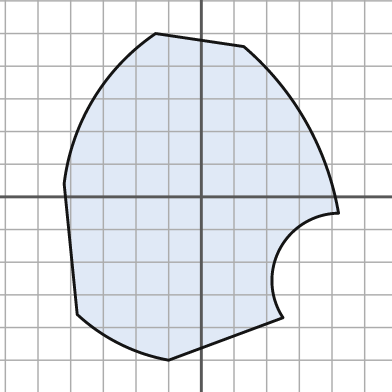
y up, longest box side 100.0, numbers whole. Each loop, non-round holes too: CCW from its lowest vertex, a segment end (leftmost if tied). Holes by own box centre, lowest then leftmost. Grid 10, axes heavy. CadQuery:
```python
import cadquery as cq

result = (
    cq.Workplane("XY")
    .moveTo(-10.0, -50.0)
    .lineTo(25.0, -37.0)
    .threePointArc((24.0, -16.0), (42.0, -5.0))
    .threePointArc((32.0, 23.0), (13.0, 46.0))
    .lineTo(-14.0, 50.0)
    .threePointArc((-33.0, 30.0), (-42.0, 4.0))
    .lineTo(-38.0, -36.0)
    .threePointArc((-25.0, -45.0), (-10.0, -50.0))
    .close()
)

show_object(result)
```